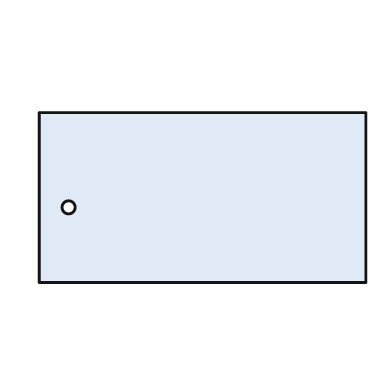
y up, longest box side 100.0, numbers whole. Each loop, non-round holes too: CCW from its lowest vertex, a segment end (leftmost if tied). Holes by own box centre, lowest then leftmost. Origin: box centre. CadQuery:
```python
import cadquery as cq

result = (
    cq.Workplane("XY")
    .moveTo(-50.0, -26.0)
    .lineTo(50.0, -26.0)
    .lineTo(50.0, 26.0)
    .lineTo(-50.0, 26.0)
    .close()
    .moveTo(-41.0, -3.0)
    .circle(2.0)
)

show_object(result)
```